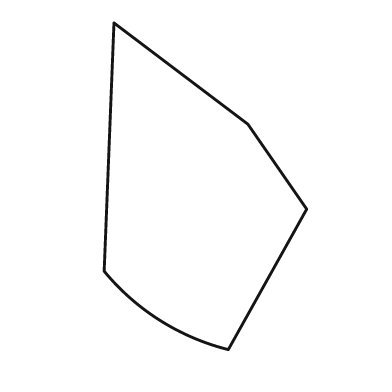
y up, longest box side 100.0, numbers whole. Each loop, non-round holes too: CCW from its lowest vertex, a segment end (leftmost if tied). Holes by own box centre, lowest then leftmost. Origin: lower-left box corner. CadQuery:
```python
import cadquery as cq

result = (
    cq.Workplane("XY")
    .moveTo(38.0, 0.0)
    .lineTo(62.0, 43.0)
    .lineTo(44.0, 69.0)
    .lineTo(3.0, 100.0)
    .lineTo(0.0, 24.0)
    .threePointArc((17.0, 9.0), (38.0, 0.0))
    .close()
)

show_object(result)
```